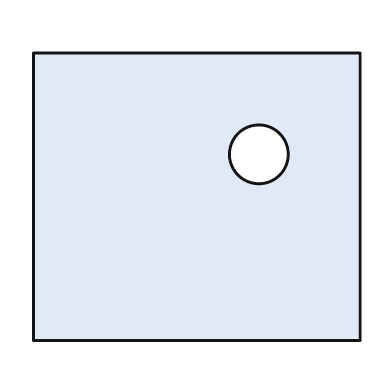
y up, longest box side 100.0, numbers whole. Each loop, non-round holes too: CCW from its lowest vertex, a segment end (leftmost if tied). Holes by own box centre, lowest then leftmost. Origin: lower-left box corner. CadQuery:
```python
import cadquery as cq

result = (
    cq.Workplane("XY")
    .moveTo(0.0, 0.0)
    .lineTo(100.0, 0.0)
    .lineTo(100.0, 88.0)
    .lineTo(0.0, 88.0)
    .close()
    .moveTo(69.0, 57.0)
    .circle(9.0)
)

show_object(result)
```